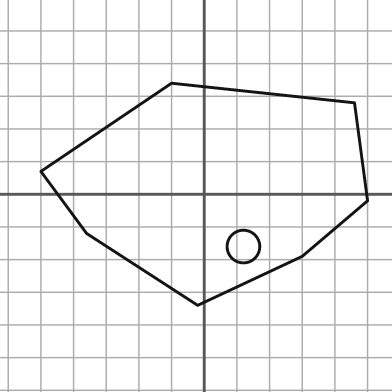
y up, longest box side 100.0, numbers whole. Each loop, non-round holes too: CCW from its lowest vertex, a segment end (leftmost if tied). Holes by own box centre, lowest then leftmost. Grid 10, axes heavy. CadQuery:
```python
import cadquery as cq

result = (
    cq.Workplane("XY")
    .moveTo(-2.0, -34.0)
    .lineTo(30.0, -19.0)
    .lineTo(50.0, -2.0)
    .lineTo(46.0, 28.0)
    .lineTo(-10.0, 34.0)
    .lineTo(-50.0, 7.0)
    .lineTo(-36.0, -12.0)
    .close()
    .moveTo(12.0, -16.0)
    .circle(5.0)
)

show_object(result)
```